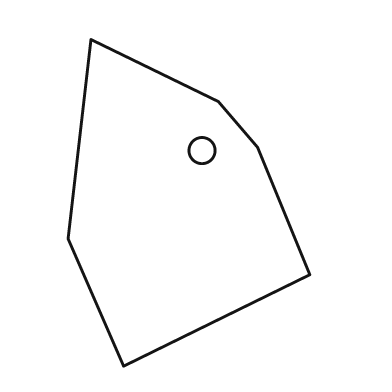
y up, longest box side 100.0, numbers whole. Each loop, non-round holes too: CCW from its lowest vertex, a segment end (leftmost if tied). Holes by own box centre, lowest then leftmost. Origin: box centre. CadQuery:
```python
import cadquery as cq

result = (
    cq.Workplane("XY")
    .moveTo(-20.0, -50.0)
    .lineTo(37.0, -22.0)
    .lineTo(21.0, 17.0)
    .lineTo(9.0, 31.0)
    .lineTo(-30.0, 50.0)
    .lineTo(-37.0, -11.0)
    .close()
    .moveTo(4.0, 16.0)
    .circle(4.0)
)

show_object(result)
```